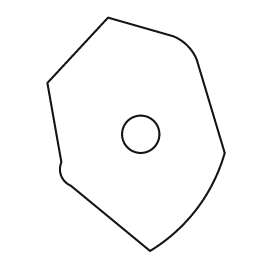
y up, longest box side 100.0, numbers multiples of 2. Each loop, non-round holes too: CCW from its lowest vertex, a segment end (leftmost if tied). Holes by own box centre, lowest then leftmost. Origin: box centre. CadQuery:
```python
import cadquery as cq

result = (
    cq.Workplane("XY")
    .moveTo(6.0, -50.0)
    .threePointArc((26.0, -32.0), (38.0, -8.0))
    .lineTo(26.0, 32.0)
    .threePointArc((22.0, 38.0), (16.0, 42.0))
    .lineTo(-12.0, 50.0)
    .lineTo(-38.0, 22.0)
    .lineTo(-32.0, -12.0)
    .threePointArc((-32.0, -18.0), (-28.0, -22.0))
    .close()
    .moveTo(2.0, 0.0)
    .circle(8.0)
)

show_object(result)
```